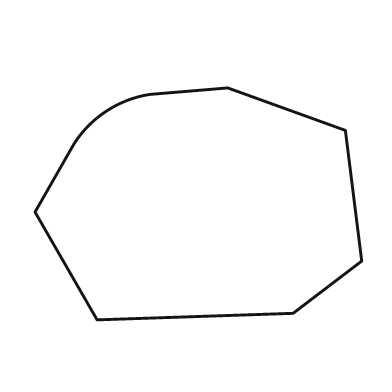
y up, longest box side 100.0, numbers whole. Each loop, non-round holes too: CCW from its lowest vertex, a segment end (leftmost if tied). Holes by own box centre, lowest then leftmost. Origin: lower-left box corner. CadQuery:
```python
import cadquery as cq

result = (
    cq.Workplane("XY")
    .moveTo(19.0, 0.0)
    .lineTo(79.0, 2.0)
    .lineTo(100.0, 18.0)
    .lineTo(95.0, 58.0)
    .lineTo(59.0, 71.0)
    .lineTo(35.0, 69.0)
    .threePointArc((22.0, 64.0), (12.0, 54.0))
    .lineTo(0.0, 33.0)
    .close()
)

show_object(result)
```